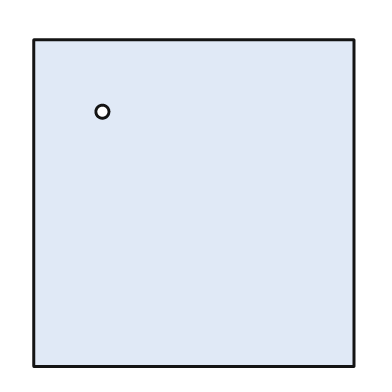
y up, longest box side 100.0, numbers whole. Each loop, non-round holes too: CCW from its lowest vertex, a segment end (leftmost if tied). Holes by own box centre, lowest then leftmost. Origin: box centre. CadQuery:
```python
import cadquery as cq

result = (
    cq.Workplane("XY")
    .moveTo(-49.0, -50.0)
    .lineTo(49.0, -50.0)
    .lineTo(49.0, 50.0)
    .lineTo(-49.0, 50.0)
    .close()
    .moveTo(-28.0, 28.0)
    .circle(2.0)
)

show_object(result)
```